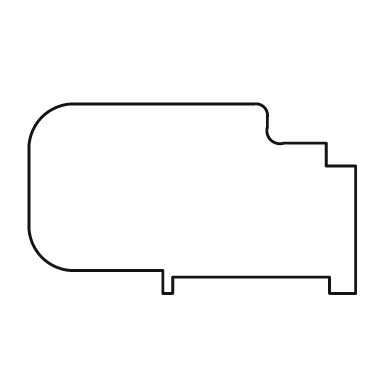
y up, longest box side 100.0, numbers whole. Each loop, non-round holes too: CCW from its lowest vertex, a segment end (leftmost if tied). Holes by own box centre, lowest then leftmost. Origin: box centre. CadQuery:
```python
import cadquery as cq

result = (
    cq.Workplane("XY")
    .moveTo(-9.0, -29.0)
    .lineTo(-6.0, -29.0)
    .lineTo(-6.0, -24.0)
    .lineTo(42.0, -24.0)
    .lineTo(42.0, -29.0)
    .lineTo(50.0, -29.0)
    .lineTo(50.0, 10.0)
    .lineTo(41.0, 10.0)
    .lineTo(41.0, 17.0)
    .lineTo(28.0, 17.0)
    .threePointArc((24.0, 18.0), (23.0, 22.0))
    .lineTo(23.0, 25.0)
    .threePointArc((22.0, 28.0), (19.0, 29.0))
    .lineTo(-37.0, 29.0)
    .threePointArc((-46.0, 25.0), (-50.0, 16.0))
    .lineTo(-50.0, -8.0)
    .threePointArc((-46.0, -18.0), (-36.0, -22.0))
    .lineTo(-9.0, -22.0)
    .close()
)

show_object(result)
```